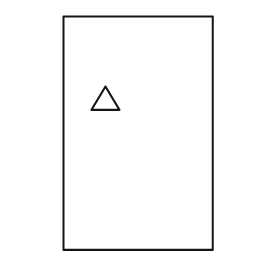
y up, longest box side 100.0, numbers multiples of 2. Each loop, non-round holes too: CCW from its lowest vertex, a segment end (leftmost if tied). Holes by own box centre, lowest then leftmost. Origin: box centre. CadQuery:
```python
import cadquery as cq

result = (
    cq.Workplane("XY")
    .moveTo(-32.0, -50.0)
    .lineTo(32.0, -50.0)
    .lineTo(32.0, 50.0)
    .lineTo(-32.0, 50.0)
    .close()
    .moveTo(-20.0, 10.0)
    .lineTo(-8.0, 10.0)
    .lineTo(-14.0, 20.0)
    .close()
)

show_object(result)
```